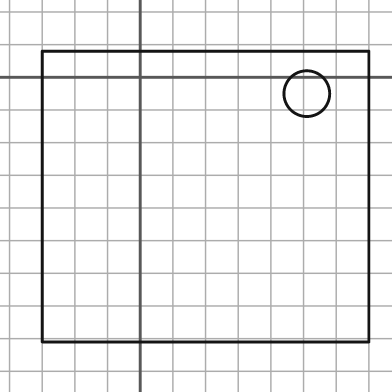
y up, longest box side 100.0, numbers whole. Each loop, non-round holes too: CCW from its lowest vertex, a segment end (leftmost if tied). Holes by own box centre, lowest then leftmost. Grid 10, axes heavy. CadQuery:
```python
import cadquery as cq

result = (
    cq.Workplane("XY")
    .moveTo(-30.0, -81.0)
    .lineTo(70.0, -81.0)
    .lineTo(70.0, 8.0)
    .lineTo(-30.0, 8.0)
    .close()
    .moveTo(51.0, -5.0)
    .circle(7.0)
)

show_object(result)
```